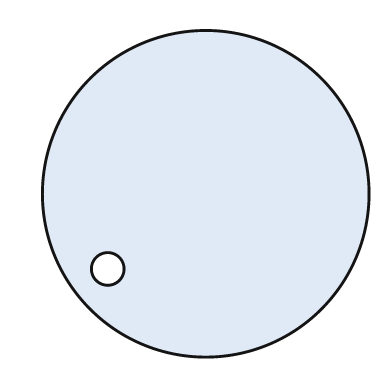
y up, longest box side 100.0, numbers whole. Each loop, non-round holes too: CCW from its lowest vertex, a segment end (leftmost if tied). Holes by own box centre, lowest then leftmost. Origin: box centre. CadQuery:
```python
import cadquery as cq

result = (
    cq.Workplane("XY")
    .moveTo(0.0, 0.0)
    .circle(50.0)
    .moveTo(-30.0, -23.0)
    .circle(5.0)
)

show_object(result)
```